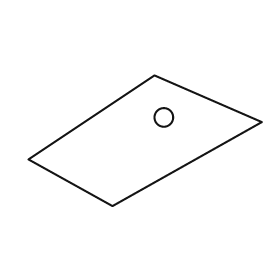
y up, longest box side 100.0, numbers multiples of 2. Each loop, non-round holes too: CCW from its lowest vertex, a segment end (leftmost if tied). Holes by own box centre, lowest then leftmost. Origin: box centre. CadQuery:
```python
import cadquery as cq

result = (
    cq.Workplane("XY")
    .moveTo(-14.0, -28.0)
    .lineTo(50.0, 8.0)
    .lineTo(4.0, 28.0)
    .lineTo(-50.0, -8.0)
    .close()
    .moveTo(8.0, 10.0)
    .circle(4.0)
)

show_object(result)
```